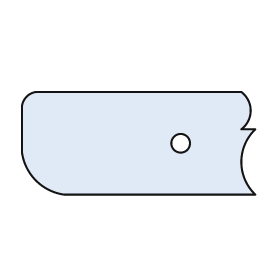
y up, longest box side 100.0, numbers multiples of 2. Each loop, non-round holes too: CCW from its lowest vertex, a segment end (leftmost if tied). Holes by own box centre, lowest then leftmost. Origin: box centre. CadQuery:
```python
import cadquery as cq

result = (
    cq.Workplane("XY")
    .moveTo(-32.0, -22.0)
    .lineTo(50.0, -22.0)
    .threePointArc((44.0, -8.0), (50.0, 6.0))
    .lineTo(44.0, 6.0)
    .threePointArc((48.0, 14.0), (44.0, 22.0))
    .lineTo(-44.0, 22.0)
    .threePointArc((-48.0, 20.0), (-50.0, 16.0))
    .lineTo(-50.0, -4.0)
    .threePointArc((-44.0, -16.0), (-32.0, -22.0))
    .close()
    .moveTo(18.0, 0.0)
    .circle(4.0)
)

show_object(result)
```